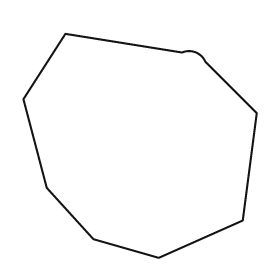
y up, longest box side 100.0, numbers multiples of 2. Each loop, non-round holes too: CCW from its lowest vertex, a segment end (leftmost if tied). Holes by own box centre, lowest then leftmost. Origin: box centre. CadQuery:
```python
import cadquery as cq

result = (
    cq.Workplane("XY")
    .moveTo(8.0, -48.0)
    .lineTo(44.0, -32.0)
    .lineTo(50.0, 14.0)
    .lineTo(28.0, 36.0)
    .threePointArc((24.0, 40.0), (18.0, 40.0))
    .lineTo(-32.0, 48.0)
    .lineTo(-50.0, 20.0)
    .lineTo(-40.0, -18.0)
    .lineTo(-20.0, -40.0)
    .close()
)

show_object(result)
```